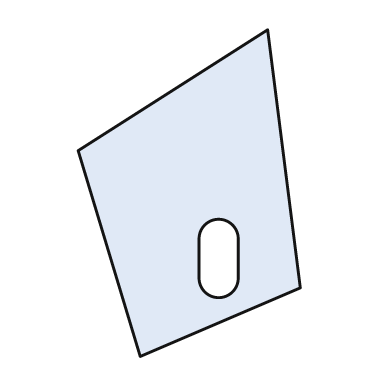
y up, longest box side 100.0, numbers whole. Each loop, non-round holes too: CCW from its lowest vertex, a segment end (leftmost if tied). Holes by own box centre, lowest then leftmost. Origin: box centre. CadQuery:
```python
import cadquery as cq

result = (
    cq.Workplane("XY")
    .moveTo(-15.0, -50.0)
    .lineTo(34.0, -29.0)
    .lineTo(24.0, 50.0)
    .lineTo(-34.0, 13.0)
    .close()
    .moveTo(3.0, -26.0)
    .threePointArc((9.0, -32.0), (15.0, -26.0))
    .lineTo(15.0, -14.0)
    .threePointArc((9.0, -8.0), (3.0, -14.0))
    .close()
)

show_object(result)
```